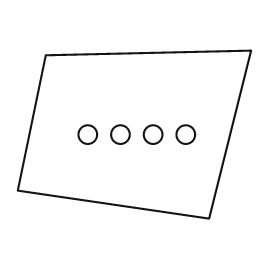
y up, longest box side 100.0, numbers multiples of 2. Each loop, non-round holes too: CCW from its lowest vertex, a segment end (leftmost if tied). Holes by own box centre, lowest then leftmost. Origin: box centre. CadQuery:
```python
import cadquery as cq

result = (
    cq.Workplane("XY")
    .moveTo(32.0, -36.0)
    .lineTo(50.0, 36.0)
    .lineTo(-38.0, 34.0)
    .lineTo(-50.0, -24.0)
    .close()
    .moveTo(-20.0, 0.0)
    .circle(4.0)
    .moveTo(-6.0, 0.0)
    .circle(4.0)
    .moveTo(8.0, 0.0)
    .circle(4.0)
    .moveTo(22.0, 0.0)
    .circle(4.0)
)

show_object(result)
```